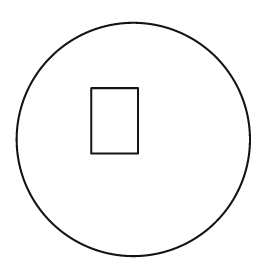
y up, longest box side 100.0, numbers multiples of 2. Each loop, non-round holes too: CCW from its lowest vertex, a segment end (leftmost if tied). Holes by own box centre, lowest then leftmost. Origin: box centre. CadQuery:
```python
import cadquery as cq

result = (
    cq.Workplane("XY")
    .moveTo(0.0, 0.0)
    .circle(50.0)
    .moveTo(-18.0, -6.0)
    .lineTo(2.0, -6.0)
    .lineTo(2.0, 22.0)
    .lineTo(-18.0, 22.0)
    .close()
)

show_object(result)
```